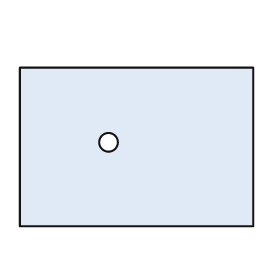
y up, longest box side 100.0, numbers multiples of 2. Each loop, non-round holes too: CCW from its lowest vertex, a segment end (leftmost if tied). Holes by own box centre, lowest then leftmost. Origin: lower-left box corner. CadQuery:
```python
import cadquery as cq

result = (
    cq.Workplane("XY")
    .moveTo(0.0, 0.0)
    .lineTo(100.0, 0.0)
    .lineTo(100.0, 68.0)
    .lineTo(0.0, 68.0)
    .close()
    .moveTo(38.0, 36.0)
    .circle(4.0)
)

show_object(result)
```